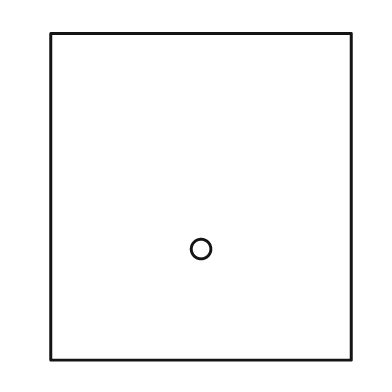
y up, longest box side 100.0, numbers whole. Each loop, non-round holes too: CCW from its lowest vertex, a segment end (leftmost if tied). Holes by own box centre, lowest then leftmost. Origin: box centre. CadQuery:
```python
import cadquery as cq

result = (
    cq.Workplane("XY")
    .moveTo(-46.0, -50.0)
    .lineTo(46.0, -50.0)
    .lineTo(46.0, 50.0)
    .lineTo(-46.0, 50.0)
    .close()
    .moveTo(0.0, -16.0)
    .circle(3.0)
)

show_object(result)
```